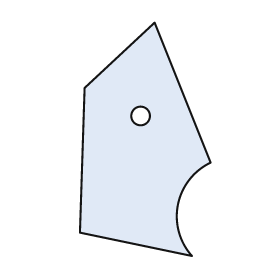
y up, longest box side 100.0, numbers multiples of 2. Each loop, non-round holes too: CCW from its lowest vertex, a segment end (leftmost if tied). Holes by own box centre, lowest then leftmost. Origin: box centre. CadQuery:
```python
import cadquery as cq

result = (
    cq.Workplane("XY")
    .moveTo(20.0, -50.0)
    .threePointArc((14.0, -28.0), (28.0, -10.0))
    .lineTo(4.0, 50.0)
    .lineTo(-26.0, 22.0)
    .lineTo(-28.0, -40.0)
    .close()
    .moveTo(-2.0, 10.0)
    .circle(4.0)
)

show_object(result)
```